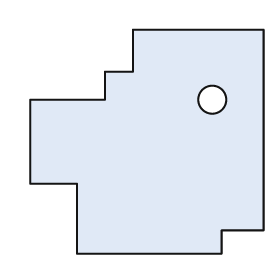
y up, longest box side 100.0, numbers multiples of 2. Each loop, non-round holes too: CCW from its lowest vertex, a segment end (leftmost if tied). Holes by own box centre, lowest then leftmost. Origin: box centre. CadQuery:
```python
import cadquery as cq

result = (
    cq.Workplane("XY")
    .moveTo(-30.0, -48.0)
    .lineTo(32.0, -48.0)
    .lineTo(32.0, -38.0)
    .lineTo(50.0, -38.0)
    .lineTo(50.0, 48.0)
    .lineTo(-6.0, 48.0)
    .lineTo(-6.0, 30.0)
    .lineTo(-18.0, 30.0)
    .lineTo(-18.0, 18.0)
    .lineTo(-50.0, 18.0)
    .lineTo(-50.0, -18.0)
    .lineTo(-30.0, -18.0)
    .close()
    .moveTo(28.0, 18.0)
    .circle(6.0)
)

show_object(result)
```